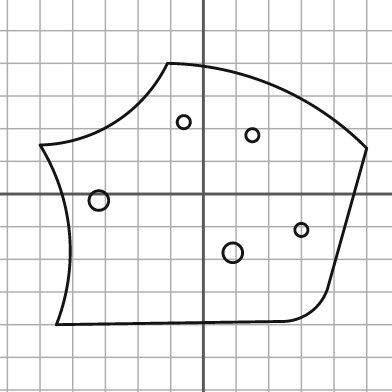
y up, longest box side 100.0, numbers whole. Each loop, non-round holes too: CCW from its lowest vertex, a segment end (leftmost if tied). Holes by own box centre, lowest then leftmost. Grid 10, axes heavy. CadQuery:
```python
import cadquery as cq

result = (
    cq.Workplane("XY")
    .moveTo(-45.0, -40.0)
    .lineTo(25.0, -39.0)
    .threePointArc((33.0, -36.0), (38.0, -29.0))
    .lineTo(50.0, 14.0)
    .threePointArc((22.0, 33.0), (-11.0, 40.0))
    .threePointArc((-27.0, 22.0), (-50.0, 15.0))
    .threePointArc((-41.0, -12.0), (-45.0, -40.0))
    .close()
    .moveTo(9.0, -18.0)
    .circle(3.0)
    .moveTo(30.0, -11.0)
    .circle(2.0)
    .moveTo(-32.0, -2.0)
    .circle(3.0)
    .moveTo(15.0, 18.0)
    .circle(2.0)
    .moveTo(-6.0, 22.0)
    .circle(2.0)
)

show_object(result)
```